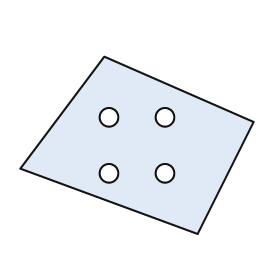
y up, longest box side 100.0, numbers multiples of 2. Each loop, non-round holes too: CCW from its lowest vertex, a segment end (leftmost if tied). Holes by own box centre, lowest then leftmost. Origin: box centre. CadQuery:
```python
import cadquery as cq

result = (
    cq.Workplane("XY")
    .moveTo(26.0, -38.0)
    .lineTo(50.0, 10.0)
    .lineTo(-14.0, 38.0)
    .lineTo(-50.0, -10.0)
    .close()
    .moveTo(-12.0, -12.0)
    .circle(4.0)
    .moveTo(12.0, -12.0)
    .circle(4.0)
    .moveTo(-12.0, 12.0)
    .circle(4.0)
    .moveTo(12.0, 12.0)
    .circle(4.0)
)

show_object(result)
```